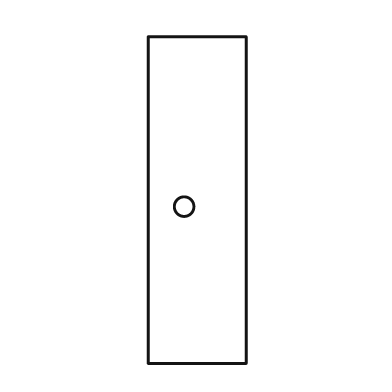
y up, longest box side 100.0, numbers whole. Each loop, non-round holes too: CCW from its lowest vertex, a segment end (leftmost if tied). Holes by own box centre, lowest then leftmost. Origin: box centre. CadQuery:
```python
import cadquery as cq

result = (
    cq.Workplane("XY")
    .moveTo(-15.0, -50.0)
    .lineTo(15.0, -50.0)
    .lineTo(15.0, 50.0)
    .lineTo(-15.0, 50.0)
    .close()
    .moveTo(-4.0, -2.0)
    .circle(3.0)
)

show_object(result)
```